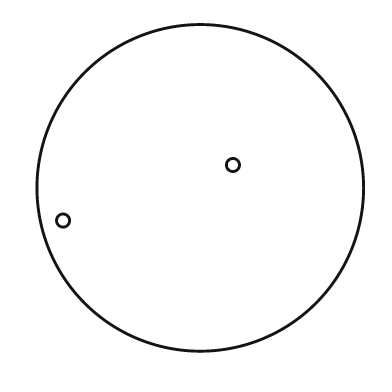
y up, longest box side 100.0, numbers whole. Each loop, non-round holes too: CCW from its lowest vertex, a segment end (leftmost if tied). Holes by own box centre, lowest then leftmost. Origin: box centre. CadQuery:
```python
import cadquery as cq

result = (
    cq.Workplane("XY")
    .moveTo(0.0, 0.0)
    .circle(50.0)
    .moveTo(-42.0, -10.0)
    .circle(2.0)
    .moveTo(10.0, 7.0)
    .circle(2.0)
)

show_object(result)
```